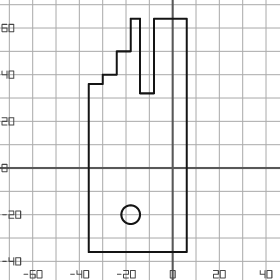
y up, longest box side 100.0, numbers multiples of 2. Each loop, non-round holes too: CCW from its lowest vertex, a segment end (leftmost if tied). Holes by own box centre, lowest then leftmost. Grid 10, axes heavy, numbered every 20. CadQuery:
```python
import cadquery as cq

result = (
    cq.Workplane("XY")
    .moveTo(-36.0, -36.0)
    .lineTo(6.0, -36.0)
    .lineTo(6.0, 64.0)
    .lineTo(-8.0, 64.0)
    .lineTo(-8.0, 32.0)
    .lineTo(-14.0, 32.0)
    .lineTo(-14.0, 64.0)
    .lineTo(-18.0, 64.0)
    .lineTo(-18.0, 50.0)
    .lineTo(-24.0, 50.0)
    .lineTo(-24.0, 40.0)
    .lineTo(-30.0, 40.0)
    .lineTo(-30.0, 36.0)
    .lineTo(-36.0, 36.0)
    .close()
    .moveTo(-18.0, -20.0)
    .circle(4.0)
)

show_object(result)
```